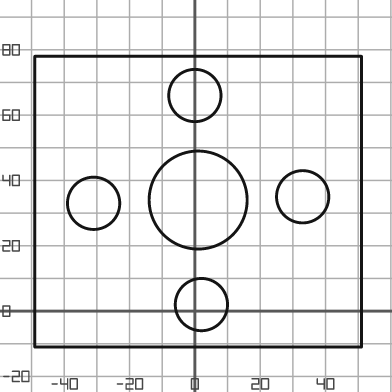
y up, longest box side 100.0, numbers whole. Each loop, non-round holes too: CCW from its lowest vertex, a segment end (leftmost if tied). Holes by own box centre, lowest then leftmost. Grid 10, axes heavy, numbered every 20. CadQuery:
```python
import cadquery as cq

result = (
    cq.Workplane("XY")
    .moveTo(-49.0, -11.0)
    .lineTo(51.0, -11.0)
    .lineTo(51.0, 78.0)
    .lineTo(-49.0, 78.0)
    .close()
    .moveTo(2.0, 2.0)
    .circle(8.0)
    .moveTo(-31.0, 33.0)
    .circle(8.0)
    .moveTo(1.0, 34.0)
    .circle(15.0)
    .moveTo(33.0, 35.0)
    .circle(8.0)
    .moveTo(0.0, 66.0)
    .circle(8.0)
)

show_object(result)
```